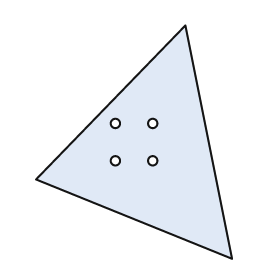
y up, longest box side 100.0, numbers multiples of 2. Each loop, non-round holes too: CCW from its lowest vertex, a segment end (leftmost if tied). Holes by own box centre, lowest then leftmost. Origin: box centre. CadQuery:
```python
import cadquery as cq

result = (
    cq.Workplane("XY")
    .moveTo(42.0, -50.0)
    .lineTo(22.0, 50.0)
    .lineTo(-42.0, -16.0)
    .close()
    .moveTo(-8.0, -8.0)
    .circle(2.0)
    .moveTo(8.0, -8.0)
    .circle(2.0)
    .moveTo(-8.0, 8.0)
    .circle(2.0)
    .moveTo(8.0, 8.0)
    .circle(2.0)
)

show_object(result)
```